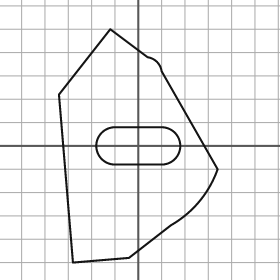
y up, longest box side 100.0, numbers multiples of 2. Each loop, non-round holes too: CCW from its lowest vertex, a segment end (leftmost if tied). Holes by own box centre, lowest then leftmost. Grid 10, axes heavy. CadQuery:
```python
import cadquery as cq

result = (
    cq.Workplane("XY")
    .moveTo(-28.0, -50.0)
    .lineTo(-4.0, -48.0)
    .lineTo(14.0, -34.0)
    .threePointArc((26.0, -24.0), (34.0, -10.0))
    .lineTo(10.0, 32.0)
    .threePointArc((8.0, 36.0), (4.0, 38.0))
    .lineTo(-12.0, 50.0)
    .lineTo(-34.0, 22.0)
    .close()
    .moveTo(-10.0, -8.0)
    .lineTo(10.0, -8.0)
    .threePointArc((18.0, 0.0), (10.0, 8.0))
    .lineTo(-10.0, 8.0)
    .threePointArc((-18.0, 0.0), (-10.0, -8.0))
    .close()
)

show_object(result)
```